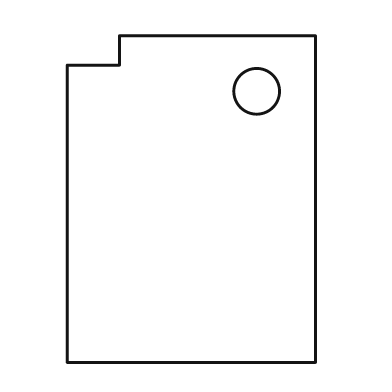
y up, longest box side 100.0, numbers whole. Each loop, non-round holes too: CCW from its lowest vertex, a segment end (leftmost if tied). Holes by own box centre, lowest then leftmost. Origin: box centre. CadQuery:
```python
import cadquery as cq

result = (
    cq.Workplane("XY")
    .moveTo(-38.0, -50.0)
    .lineTo(38.0, -50.0)
    .lineTo(38.0, 50.0)
    .lineTo(-22.0, 50.0)
    .lineTo(-22.0, 41.0)
    .lineTo(-38.0, 41.0)
    .close()
    .moveTo(20.0, 33.0)
    .circle(7.0)
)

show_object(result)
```